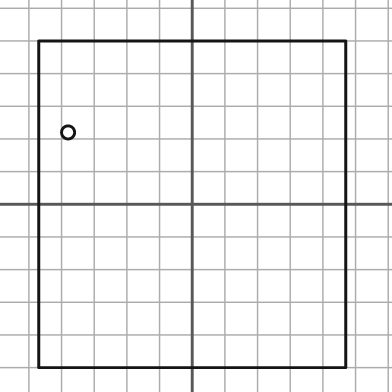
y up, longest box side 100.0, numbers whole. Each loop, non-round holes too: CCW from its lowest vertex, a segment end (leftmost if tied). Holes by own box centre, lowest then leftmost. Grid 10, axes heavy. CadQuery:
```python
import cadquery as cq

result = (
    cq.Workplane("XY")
    .moveTo(-47.0, -50.0)
    .lineTo(47.0, -50.0)
    .lineTo(47.0, 50.0)
    .lineTo(-47.0, 50.0)
    .close()
    .moveTo(-38.0, 22.0)
    .circle(2.0)
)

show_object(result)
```